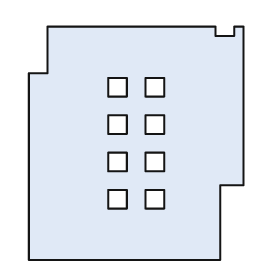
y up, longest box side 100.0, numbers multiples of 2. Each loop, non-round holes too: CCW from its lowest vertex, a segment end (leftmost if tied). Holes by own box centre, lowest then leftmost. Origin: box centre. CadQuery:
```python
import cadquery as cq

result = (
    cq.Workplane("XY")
    .moveTo(-46.0, -50.0)
    .lineTo(36.0, -50.0)
    .lineTo(36.0, -18.0)
    .lineTo(46.0, -18.0)
    .lineTo(46.0, 50.0)
    .lineTo(42.0, 50.0)
    .lineTo(42.0, 46.0)
    .lineTo(34.0, 46.0)
    .lineTo(34.0, 50.0)
    .lineTo(-38.0, 50.0)
    .lineTo(-38.0, 30.0)
    .lineTo(-46.0, 30.0)
    .close()
    .moveTo(-12.0, -28.0)
    .lineTo(-4.0, -28.0)
    .lineTo(-4.0, -20.0)
    .lineTo(-12.0, -20.0)
    .close()
    .moveTo(4.0, -28.0)
    .lineTo(12.0, -28.0)
    .lineTo(12.0, -20.0)
    .lineTo(4.0, -20.0)
    .close()
    .moveTo(-12.0, -12.0)
    .lineTo(-4.0, -12.0)
    .lineTo(-4.0, -4.0)
    .lineTo(-12.0, -4.0)
    .close()
    .moveTo(4.0, -12.0)
    .lineTo(12.0, -12.0)
    .lineTo(12.0, -4.0)
    .lineTo(4.0, -4.0)
    .close()
    .moveTo(-12.0, 4.0)
    .lineTo(-4.0, 4.0)
    .lineTo(-4.0, 12.0)
    .lineTo(-12.0, 12.0)
    .close()
    .moveTo(4.0, 4.0)
    .lineTo(12.0, 4.0)
    .lineTo(12.0, 12.0)
    .lineTo(4.0, 12.0)
    .close()
    .moveTo(-12.0, 20.0)
    .lineTo(-4.0, 20.0)
    .lineTo(-4.0, 28.0)
    .lineTo(-12.0, 28.0)
    .close()
    .moveTo(4.0, 20.0)
    .lineTo(12.0, 20.0)
    .lineTo(12.0, 28.0)
    .lineTo(4.0, 28.0)
    .close()
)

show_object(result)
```